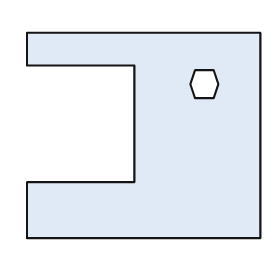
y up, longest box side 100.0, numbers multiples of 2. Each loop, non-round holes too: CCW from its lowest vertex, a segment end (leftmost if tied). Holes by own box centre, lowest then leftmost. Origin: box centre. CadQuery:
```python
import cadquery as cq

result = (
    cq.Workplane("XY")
    .moveTo(-50.0, -44.0)
    .lineTo(50.0, -44.0)
    .lineTo(50.0, 44.0)
    .lineTo(-50.0, 44.0)
    .lineTo(-50.0, 30.0)
    .lineTo(-4.0, 30.0)
    .lineTo(-4.0, -20.0)
    .lineTo(-50.0, -20.0)
    .close()
    .moveTo(22.0, 16.0)
    .lineTo(30.0, 16.0)
    .lineTo(32.0, 22.0)
    .lineTo(30.0, 28.0)
    .lineTo(22.0, 28.0)
    .lineTo(20.0, 22.0)
    .close()
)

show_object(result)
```